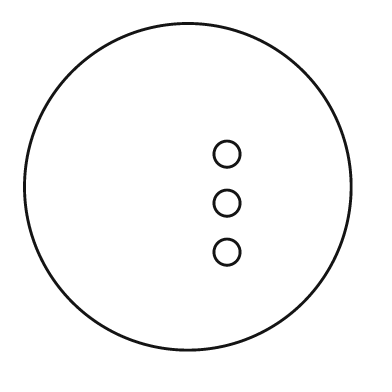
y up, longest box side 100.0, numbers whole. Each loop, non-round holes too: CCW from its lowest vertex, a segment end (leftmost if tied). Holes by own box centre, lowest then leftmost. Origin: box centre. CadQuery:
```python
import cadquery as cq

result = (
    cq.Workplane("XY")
    .moveTo(0.0, 0.0)
    .circle(50.0)
    .moveTo(12.0, -20.0)
    .circle(4.0)
    .moveTo(12.0, -5.0)
    .circle(4.0)
    .moveTo(12.0, 10.0)
    .circle(4.0)
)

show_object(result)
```